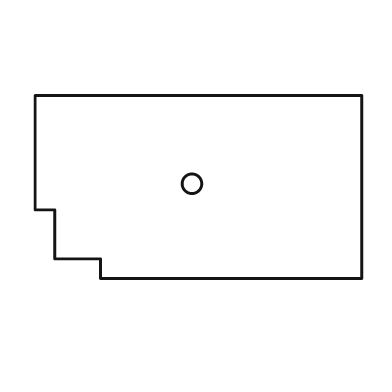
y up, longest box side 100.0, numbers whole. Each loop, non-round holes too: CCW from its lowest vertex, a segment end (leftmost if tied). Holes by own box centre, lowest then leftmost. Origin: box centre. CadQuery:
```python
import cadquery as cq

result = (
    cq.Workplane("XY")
    .moveTo(-30.0, -28.0)
    .lineTo(50.0, -28.0)
    .lineTo(50.0, 28.0)
    .lineTo(-50.0, 28.0)
    .lineTo(-50.0, -7.0)
    .lineTo(-44.0, -7.0)
    .lineTo(-44.0, -22.0)
    .lineTo(-30.0, -22.0)
    .close()
    .moveTo(-2.0, 1.0)
    .circle(3.0)
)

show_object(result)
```